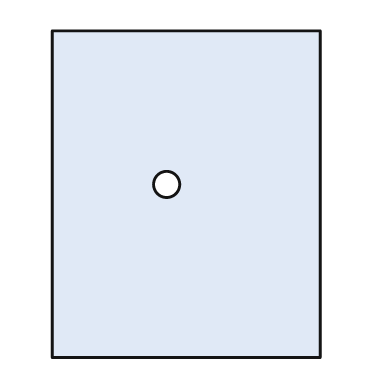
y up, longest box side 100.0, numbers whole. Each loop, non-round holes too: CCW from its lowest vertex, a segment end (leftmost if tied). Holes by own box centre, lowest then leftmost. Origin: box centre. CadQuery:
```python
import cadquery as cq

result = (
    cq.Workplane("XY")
    .moveTo(-41.0, -50.0)
    .lineTo(41.0, -50.0)
    .lineTo(41.0, 50.0)
    .lineTo(-41.0, 50.0)
    .close()
    .moveTo(-6.0, 3.0)
    .circle(4.0)
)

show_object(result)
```